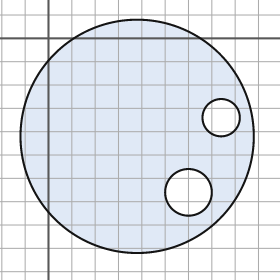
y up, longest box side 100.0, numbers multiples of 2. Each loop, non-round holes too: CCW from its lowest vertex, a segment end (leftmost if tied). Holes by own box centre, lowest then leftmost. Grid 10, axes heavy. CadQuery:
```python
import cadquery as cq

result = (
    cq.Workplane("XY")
    .moveTo(38.0, -42.0)
    .circle(50.0)
    .moveTo(60.0, -66.0)
    .circle(10.0)
    .moveTo(74.0, -34.0)
    .circle(8.0)
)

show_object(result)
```